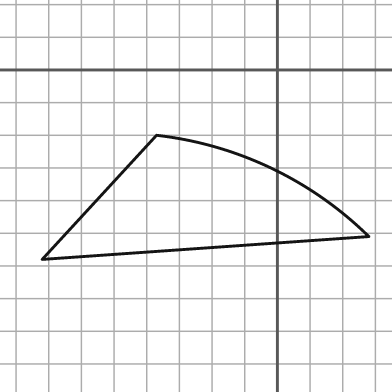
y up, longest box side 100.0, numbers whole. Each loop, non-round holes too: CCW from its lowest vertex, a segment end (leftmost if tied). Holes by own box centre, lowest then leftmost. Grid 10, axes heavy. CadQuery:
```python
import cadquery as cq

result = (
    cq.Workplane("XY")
    .moveTo(-72.0, -58.0)
    .lineTo(28.0, -51.0)
    .threePointArc((-2.0, -30.0), (-37.0, -20.0))
    .close()
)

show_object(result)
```